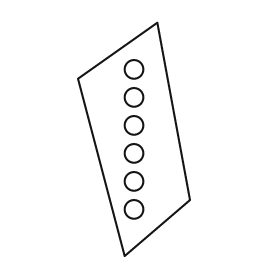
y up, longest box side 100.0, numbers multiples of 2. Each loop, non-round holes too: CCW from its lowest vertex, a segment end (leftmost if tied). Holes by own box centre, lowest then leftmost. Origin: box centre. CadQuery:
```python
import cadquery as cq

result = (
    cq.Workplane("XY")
    .moveTo(-4.0, -50.0)
    .lineTo(24.0, -26.0)
    .lineTo(10.0, 50.0)
    .lineTo(-24.0, 26.0)
    .close()
    .moveTo(0.0, -30.0)
    .circle(4.0)
    .moveTo(0.0, -18.0)
    .circle(4.0)
    .moveTo(0.0, -6.0)
    .circle(4.0)
    .moveTo(0.0, 6.0)
    .circle(4.0)
    .moveTo(0.0, 18.0)
    .circle(4.0)
    .moveTo(0.0, 30.0)
    .circle(4.0)
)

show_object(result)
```